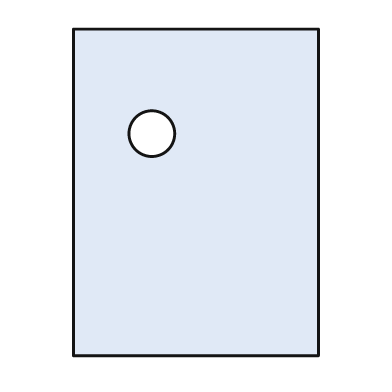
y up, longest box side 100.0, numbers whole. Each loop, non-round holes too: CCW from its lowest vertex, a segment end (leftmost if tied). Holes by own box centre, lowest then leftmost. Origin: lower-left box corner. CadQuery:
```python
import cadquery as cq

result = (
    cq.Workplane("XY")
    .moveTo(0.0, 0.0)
    .lineTo(75.0, 0.0)
    .lineTo(75.0, 100.0)
    .lineTo(0.0, 100.0)
    .close()
    .moveTo(24.0, 68.0)
    .circle(7.0)
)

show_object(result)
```